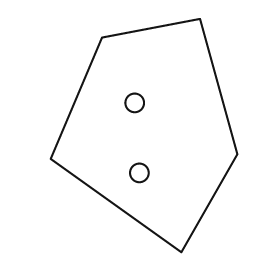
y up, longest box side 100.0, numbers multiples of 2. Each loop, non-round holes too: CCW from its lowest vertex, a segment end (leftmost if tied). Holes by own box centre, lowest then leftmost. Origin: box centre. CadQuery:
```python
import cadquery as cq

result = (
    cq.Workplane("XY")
    .moveTo(16.0, -50.0)
    .lineTo(40.0, -8.0)
    .lineTo(24.0, 50.0)
    .lineTo(-18.0, 42.0)
    .lineTo(-40.0, -10.0)
    .close()
    .moveTo(-2.0, -16.0)
    .circle(4.0)
    .moveTo(-4.0, 14.0)
    .circle(4.0)
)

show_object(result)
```